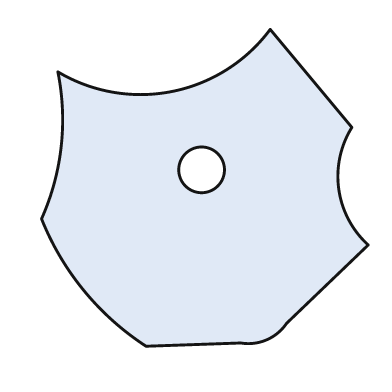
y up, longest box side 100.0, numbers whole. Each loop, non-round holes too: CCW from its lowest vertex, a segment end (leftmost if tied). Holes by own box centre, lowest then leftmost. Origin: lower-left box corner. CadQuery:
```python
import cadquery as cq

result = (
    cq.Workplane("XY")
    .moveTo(32.0, 0.0)
    .lineTo(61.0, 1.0)
    .threePointArc((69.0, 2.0), (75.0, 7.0))
    .lineTo(100.0, 31.0)
    .threePointArc((91.0, 48.0), (95.0, 67.0))
    .lineTo(70.0, 97.0)
    .threePointArc((40.0, 78.0), (5.0, 84.0))
    .threePointArc((6.0, 61.0), (0.0, 39.0))
    .threePointArc((13.0, 17.0), (32.0, 0.0))
    .close()
    .moveTo(49.0, 54.0)
    .circle(7.0)
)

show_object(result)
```